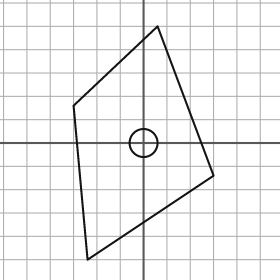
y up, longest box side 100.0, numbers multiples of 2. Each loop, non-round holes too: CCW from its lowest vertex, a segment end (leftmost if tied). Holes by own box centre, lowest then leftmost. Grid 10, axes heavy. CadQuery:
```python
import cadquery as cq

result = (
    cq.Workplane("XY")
    .moveTo(-24.0, -50.0)
    .lineTo(30.0, -14.0)
    .lineTo(6.0, 50.0)
    .lineTo(-30.0, 16.0)
    .close()
    .moveTo(0.0, 0.0)
    .circle(6.0)
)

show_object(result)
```